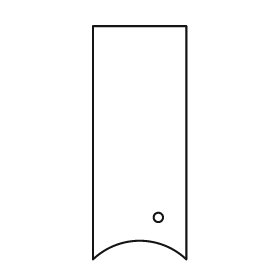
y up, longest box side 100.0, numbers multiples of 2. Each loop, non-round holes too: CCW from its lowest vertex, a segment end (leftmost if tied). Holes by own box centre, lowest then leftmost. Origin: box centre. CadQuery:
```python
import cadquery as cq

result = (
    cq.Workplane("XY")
    .moveTo(-20.0, -50.0)
    .threePointArc((0.0, -42.0), (20.0, -50.0))
    .lineTo(20.0, 50.0)
    .lineTo(-20.0, 50.0)
    .close()
    .moveTo(8.0, -32.0)
    .circle(2.0)
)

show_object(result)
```